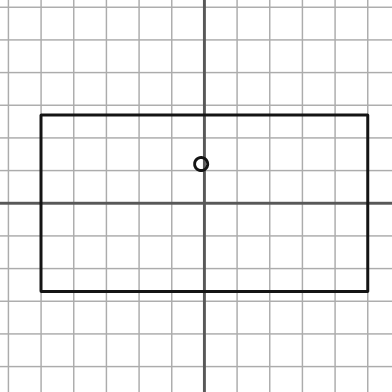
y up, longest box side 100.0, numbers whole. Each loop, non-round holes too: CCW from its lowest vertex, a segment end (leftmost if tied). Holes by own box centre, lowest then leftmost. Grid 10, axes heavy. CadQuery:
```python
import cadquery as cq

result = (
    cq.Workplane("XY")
    .moveTo(-50.0, -27.0)
    .lineTo(50.0, -27.0)
    .lineTo(50.0, 27.0)
    .lineTo(-50.0, 27.0)
    .close()
    .moveTo(-1.0, 12.0)
    .circle(2.0)
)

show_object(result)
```